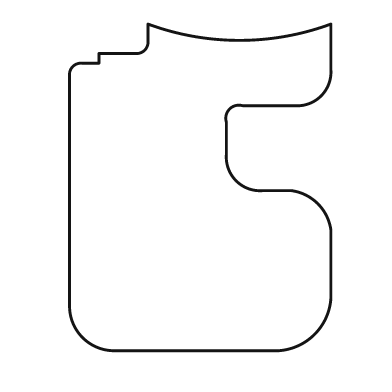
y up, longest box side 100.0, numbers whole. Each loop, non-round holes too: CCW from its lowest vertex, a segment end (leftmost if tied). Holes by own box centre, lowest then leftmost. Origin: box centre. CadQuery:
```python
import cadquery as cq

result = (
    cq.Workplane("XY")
    .moveTo(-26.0, -50.0)
    .lineTo(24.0, -50.0)
    .threePointArc((35.0, -45.0), (40.0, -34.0))
    .lineTo(40.0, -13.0)
    .threePointArc((36.0, -5.0), (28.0, -1.0))
    .lineTo(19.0, -1.0)
    .threePointArc((11.0, 2.0), (8.0, 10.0))
    .lineTo(8.0, 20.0)
    .threePointArc((9.0, 24.0), (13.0, 25.0))
    .lineTo(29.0, 25.0)
    .threePointArc((37.0, 28.0), (40.0, 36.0))
    .lineTo(40.0, 50.0)
    .threePointArc((12.0, 45.0), (-16.0, 50.0))
    .lineTo(-16.0, 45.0)
    .threePointArc((-17.0, 42.0), (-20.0, 41.0))
    .lineTo(-31.0, 41.0)
    .lineTo(-31.0, 38.0)
    .lineTo(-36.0, 38.0)
    .threePointArc((-39.0, 37.0), (-40.0, 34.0))
    .lineTo(-40.0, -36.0)
    .threePointArc((-36.0, -46.0), (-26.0, -50.0))
    .close()
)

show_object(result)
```